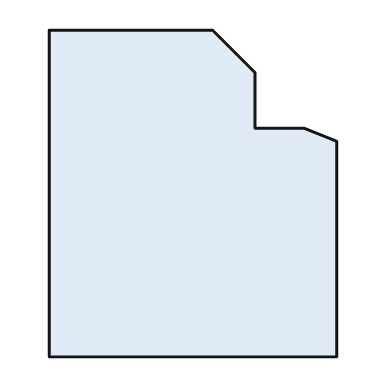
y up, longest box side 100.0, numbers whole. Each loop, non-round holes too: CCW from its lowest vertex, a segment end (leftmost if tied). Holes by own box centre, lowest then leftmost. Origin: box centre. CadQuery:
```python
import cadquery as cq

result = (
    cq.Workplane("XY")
    .moveTo(-44.0, -50.0)
    .lineTo(44.0, -50.0)
    .lineTo(44.0, 16.0)
    .lineTo(34.0, 20.0)
    .lineTo(19.0, 20.0)
    .lineTo(19.0, 37.0)
    .lineTo(6.0, 50.0)
    .lineTo(-44.0, 50.0)
    .close()
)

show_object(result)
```